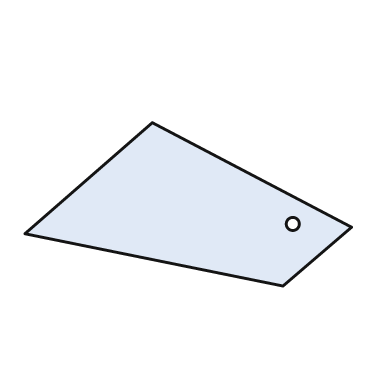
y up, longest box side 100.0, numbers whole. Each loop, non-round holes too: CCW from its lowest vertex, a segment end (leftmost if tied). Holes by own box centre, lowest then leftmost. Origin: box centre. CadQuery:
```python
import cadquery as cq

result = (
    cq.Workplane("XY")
    .moveTo(29.0, -25.0)
    .lineTo(50.0, -7.0)
    .lineTo(-11.0, 25.0)
    .lineTo(-50.0, -9.0)
    .close()
    .moveTo(32.0, -6.0)
    .circle(2.0)
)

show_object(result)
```